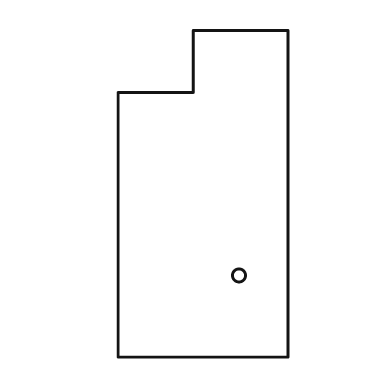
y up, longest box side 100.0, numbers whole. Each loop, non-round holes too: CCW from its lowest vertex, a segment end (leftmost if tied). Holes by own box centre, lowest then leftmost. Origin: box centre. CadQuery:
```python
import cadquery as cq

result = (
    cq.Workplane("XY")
    .moveTo(-26.0, -50.0)
    .lineTo(26.0, -50.0)
    .lineTo(26.0, 50.0)
    .lineTo(-3.0, 50.0)
    .lineTo(-3.0, 31.0)
    .lineTo(-26.0, 31.0)
    .close()
    .moveTo(11.0, -25.0)
    .circle(2.0)
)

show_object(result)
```